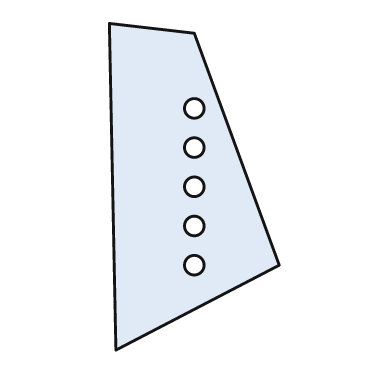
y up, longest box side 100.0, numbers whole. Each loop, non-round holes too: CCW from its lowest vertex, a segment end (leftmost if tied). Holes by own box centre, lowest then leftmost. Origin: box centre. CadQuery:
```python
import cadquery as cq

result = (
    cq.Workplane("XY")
    .moveTo(-24.0, -50.0)
    .lineTo(26.0, -24.0)
    .lineTo(0.0, 47.0)
    .lineTo(-26.0, 50.0)
    .close()
    .moveTo(0.0, -24.0)
    .circle(3.0)
    .moveTo(0.0, -12.0)
    .circle(3.0)
    .moveTo(0.0, 0.0)
    .circle(3.0)
    .moveTo(0.0, 12.0)
    .circle(3.0)
    .moveTo(0.0, 24.0)
    .circle(3.0)
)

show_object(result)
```